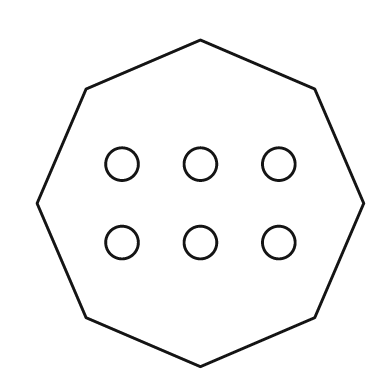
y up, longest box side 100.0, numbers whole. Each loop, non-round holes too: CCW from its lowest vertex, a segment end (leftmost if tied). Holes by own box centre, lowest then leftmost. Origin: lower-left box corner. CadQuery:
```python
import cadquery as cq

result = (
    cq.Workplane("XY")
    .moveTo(50.0, 0.0)
    .lineTo(85.0, 15.0)
    .lineTo(100.0, 50.0)
    .lineTo(85.0, 85.0)
    .lineTo(50.0, 100.0)
    .lineTo(15.0, 85.0)
    .lineTo(0.0, 50.0)
    .lineTo(15.0, 15.0)
    .close()
    .moveTo(26.0, 38.0)
    .circle(5.0)
    .moveTo(50.0, 38.0)
    .circle(5.0)
    .moveTo(74.0, 38.0)
    .circle(5.0)
    .moveTo(26.0, 62.0)
    .circle(5.0)
    .moveTo(50.0, 62.0)
    .circle(5.0)
    .moveTo(74.0, 62.0)
    .circle(5.0)
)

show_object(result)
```